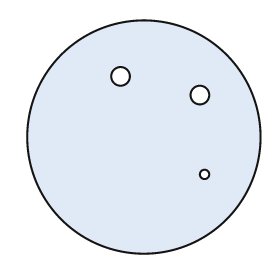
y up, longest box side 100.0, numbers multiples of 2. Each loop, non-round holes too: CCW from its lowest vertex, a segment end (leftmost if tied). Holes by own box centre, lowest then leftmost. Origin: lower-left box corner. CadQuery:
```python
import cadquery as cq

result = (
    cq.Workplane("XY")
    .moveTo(50.0, 50.0)
    .circle(50.0)
    .moveTo(76.0, 34.0)
    .circle(2.0)
    .moveTo(74.0, 68.0)
    .circle(4.0)
    .moveTo(40.0, 76.0)
    .circle(4.0)
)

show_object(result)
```